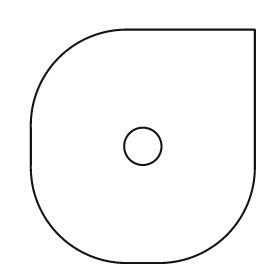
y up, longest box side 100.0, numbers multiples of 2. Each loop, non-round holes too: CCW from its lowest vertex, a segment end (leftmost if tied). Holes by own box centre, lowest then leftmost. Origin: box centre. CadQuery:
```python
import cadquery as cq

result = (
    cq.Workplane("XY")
    .moveTo(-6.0, -50.0)
    .lineTo(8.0, -50.0)
    .threePointArc((36.0, -38.0), (48.0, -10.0))
    .lineTo(48.0, 50.0)
    .lineTo(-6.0, 50.0)
    .threePointArc((-36.0, 38.0), (-48.0, 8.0))
    .lineTo(-48.0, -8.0)
    .threePointArc((-36.0, -38.0), (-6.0, -50.0))
    .close()
    .moveTo(0.0, 0.0)
    .circle(8.0)
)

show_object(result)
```